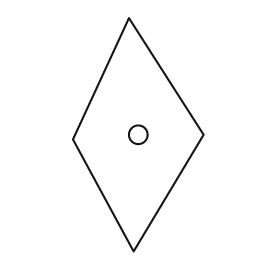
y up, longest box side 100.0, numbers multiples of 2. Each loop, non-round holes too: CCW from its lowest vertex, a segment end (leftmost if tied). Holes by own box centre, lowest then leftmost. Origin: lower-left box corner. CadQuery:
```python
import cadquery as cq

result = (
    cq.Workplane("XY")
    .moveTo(26.0, 0.0)
    .lineTo(56.0, 50.0)
    .lineTo(24.0, 100.0)
    .lineTo(0.0, 48.0)
    .close()
    .moveTo(28.0, 50.0)
    .circle(4.0)
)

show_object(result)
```